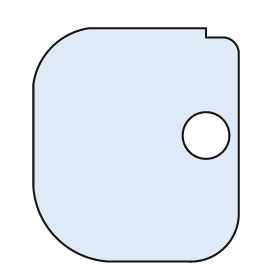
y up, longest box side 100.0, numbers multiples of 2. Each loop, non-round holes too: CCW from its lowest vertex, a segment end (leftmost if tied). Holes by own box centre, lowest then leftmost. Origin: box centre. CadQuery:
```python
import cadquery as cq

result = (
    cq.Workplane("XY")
    .moveTo(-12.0, -50.0)
    .lineTo(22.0, -50.0)
    .threePointArc((38.0, -44.0), (44.0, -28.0))
    .lineTo(44.0, 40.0)
    .threePointArc((42.0, 44.0), (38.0, 46.0))
    .lineTo(30.0, 46.0)
    .lineTo(30.0, 50.0)
    .lineTo(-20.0, 50.0)
    .threePointArc((-36.0, 42.0), (-44.0, 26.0))
    .lineTo(-44.0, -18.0)
    .threePointArc((-34.0, -40.0), (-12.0, -50.0))
    .close()
    .moveTo(30.0, 4.0)
    .circle(10.0)
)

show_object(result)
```